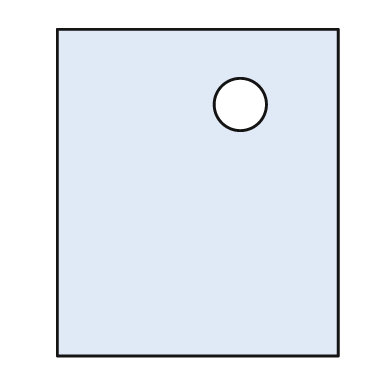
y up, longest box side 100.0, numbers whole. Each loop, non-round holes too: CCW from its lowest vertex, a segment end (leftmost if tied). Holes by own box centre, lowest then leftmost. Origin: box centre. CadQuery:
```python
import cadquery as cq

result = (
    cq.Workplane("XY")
    .moveTo(-43.0, -50.0)
    .lineTo(43.0, -50.0)
    .lineTo(43.0, 50.0)
    .lineTo(-43.0, 50.0)
    .close()
    .moveTo(13.0, 27.0)
    .circle(8.0)
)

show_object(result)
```